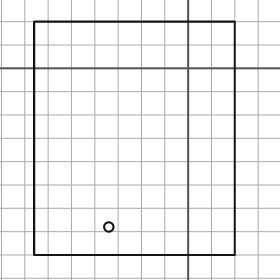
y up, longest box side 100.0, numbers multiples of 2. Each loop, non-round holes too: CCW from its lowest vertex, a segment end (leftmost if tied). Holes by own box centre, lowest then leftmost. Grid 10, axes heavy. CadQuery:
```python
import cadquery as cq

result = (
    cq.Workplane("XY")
    .moveTo(-66.0, -80.0)
    .lineTo(20.0, -80.0)
    .lineTo(20.0, 20.0)
    .lineTo(-66.0, 20.0)
    .close()
    .moveTo(-34.0, -68.0)
    .circle(2.0)
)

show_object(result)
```